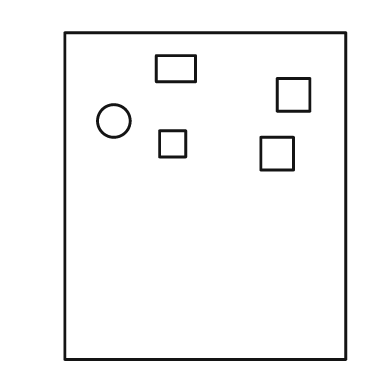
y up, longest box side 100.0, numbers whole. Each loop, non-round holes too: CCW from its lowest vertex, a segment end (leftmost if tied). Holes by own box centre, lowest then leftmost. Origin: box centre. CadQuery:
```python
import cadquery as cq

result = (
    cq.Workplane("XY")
    .moveTo(-43.0, -50.0)
    .lineTo(43.0, -50.0)
    .lineTo(43.0, 50.0)
    .lineTo(-43.0, 50.0)
    .close()
    .moveTo(17.0, 8.0)
    .lineTo(27.0, 8.0)
    .lineTo(27.0, 18.0)
    .lineTo(17.0, 18.0)
    .close()
    .moveTo(-14.0, 12.0)
    .lineTo(-6.0, 12.0)
    .lineTo(-6.0, 20.0)
    .lineTo(-14.0, 20.0)
    .close()
    .moveTo(-28.0, 23.0)
    .circle(5.0)
    .moveTo(22.0, 26.0)
    .lineTo(32.0, 26.0)
    .lineTo(32.0, 36.0)
    .lineTo(22.0, 36.0)
    .close()
    .moveTo(-15.0, 35.0)
    .lineTo(-3.0, 35.0)
    .lineTo(-3.0, 43.0)
    .lineTo(-15.0, 43.0)
    .close()
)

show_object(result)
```